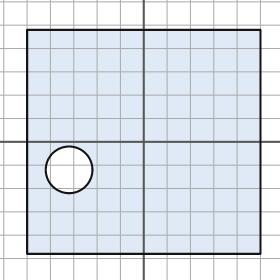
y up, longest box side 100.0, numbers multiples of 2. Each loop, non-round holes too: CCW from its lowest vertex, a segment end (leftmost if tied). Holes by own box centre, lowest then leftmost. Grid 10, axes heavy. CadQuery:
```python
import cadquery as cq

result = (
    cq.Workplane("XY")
    .moveTo(-50.0, -48.0)
    .lineTo(50.0, -48.0)
    .lineTo(50.0, 48.0)
    .lineTo(-50.0, 48.0)
    .close()
    .moveTo(-32.0, -12.0)
    .circle(10.0)
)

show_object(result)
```